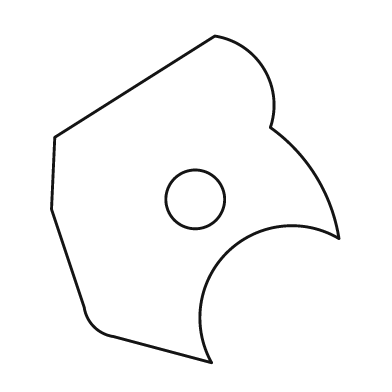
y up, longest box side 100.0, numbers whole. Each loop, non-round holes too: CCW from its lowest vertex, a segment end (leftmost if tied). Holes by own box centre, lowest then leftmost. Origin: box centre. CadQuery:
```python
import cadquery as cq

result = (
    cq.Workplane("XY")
    .moveTo(5.0, -50.0)
    .threePointArc((10.0, -16.0), (44.0, -12.0))
    .threePointArc((37.0, 7.0), (23.0, 22.0))
    .threePointArc((21.0, 40.0), (6.0, 50.0))
    .lineTo(-43.0, 19.0)
    .lineTo(-44.0, -3.0)
    .lineTo(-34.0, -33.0)
    .threePointArc((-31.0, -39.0), (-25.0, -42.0))
    .close()
    .moveTo(0.0, 0.0)
    .circle(9.0)
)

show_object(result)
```